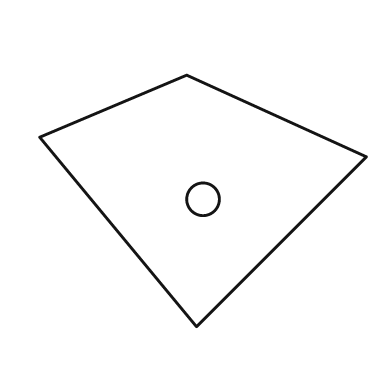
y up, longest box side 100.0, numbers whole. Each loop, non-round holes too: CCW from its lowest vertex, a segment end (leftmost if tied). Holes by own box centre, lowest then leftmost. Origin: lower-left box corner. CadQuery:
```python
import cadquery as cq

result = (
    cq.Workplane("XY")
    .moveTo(48.0, 0.0)
    .lineTo(100.0, 52.0)
    .lineTo(45.0, 77.0)
    .lineTo(0.0, 58.0)
    .close()
    .moveTo(50.0, 39.0)
    .circle(5.0)
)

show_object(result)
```